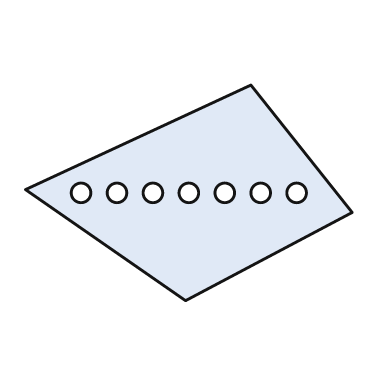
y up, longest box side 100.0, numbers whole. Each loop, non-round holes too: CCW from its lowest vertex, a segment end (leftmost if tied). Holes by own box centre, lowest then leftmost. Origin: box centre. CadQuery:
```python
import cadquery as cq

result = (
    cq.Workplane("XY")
    .moveTo(-1.0, -33.0)
    .lineTo(50.0, -6.0)
    .lineTo(19.0, 33.0)
    .lineTo(-50.0, 1.0)
    .close()
    .moveTo(-33.0, 0.0)
    .circle(3.0)
    .moveTo(-22.0, 0.0)
    .circle(3.0)
    .moveTo(-11.0, 0.0)
    .circle(3.0)
    .moveTo(0.0, 0.0)
    .circle(3.0)
    .moveTo(11.0, 0.0)
    .circle(3.0)
    .moveTo(22.0, 0.0)
    .circle(3.0)
    .moveTo(33.0, 0.0)
    .circle(3.0)
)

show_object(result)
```